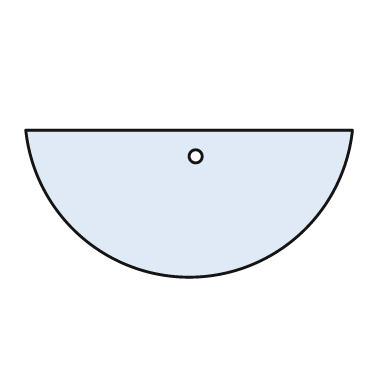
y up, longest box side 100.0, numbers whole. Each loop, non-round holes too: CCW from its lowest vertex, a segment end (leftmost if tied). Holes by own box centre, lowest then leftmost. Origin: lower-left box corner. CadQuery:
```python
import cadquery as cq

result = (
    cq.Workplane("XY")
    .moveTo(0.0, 45.0)
    .threePointArc((50.0, 0.0), (100.0, 45.0))
    .close()
    .moveTo(52.0, 37.0)
    .circle(2.0)
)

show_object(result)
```